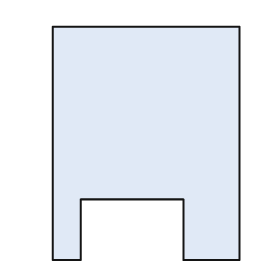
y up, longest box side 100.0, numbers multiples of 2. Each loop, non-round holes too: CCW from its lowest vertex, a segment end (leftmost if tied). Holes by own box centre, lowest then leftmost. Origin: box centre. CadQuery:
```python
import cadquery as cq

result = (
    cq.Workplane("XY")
    .moveTo(-40.0, -50.0)
    .lineTo(-28.0, -50.0)
    .lineTo(-28.0, -24.0)
    .lineTo(16.0, -24.0)
    .lineTo(16.0, -50.0)
    .lineTo(40.0, -50.0)
    .lineTo(40.0, 50.0)
    .lineTo(-40.0, 50.0)
    .close()
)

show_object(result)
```